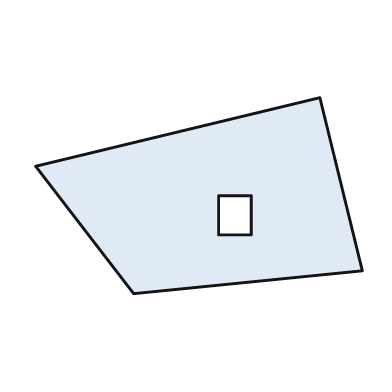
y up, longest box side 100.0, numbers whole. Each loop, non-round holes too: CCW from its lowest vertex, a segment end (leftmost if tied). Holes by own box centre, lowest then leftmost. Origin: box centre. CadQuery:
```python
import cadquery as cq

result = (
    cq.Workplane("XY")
    .moveTo(-20.0, -30.0)
    .lineTo(50.0, -23.0)
    .lineTo(37.0, 30.0)
    .lineTo(-50.0, 9.0)
    .close()
    .moveTo(6.0, -12.0)
    .lineTo(16.0, -12.0)
    .lineTo(16.0, 0.0)
    .lineTo(6.0, 0.0)
    .close()
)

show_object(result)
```